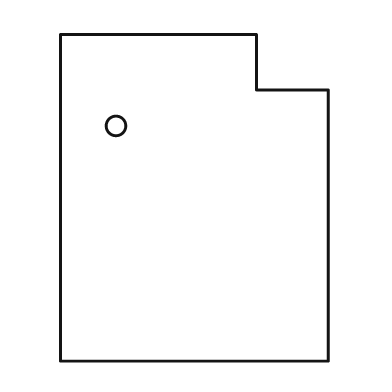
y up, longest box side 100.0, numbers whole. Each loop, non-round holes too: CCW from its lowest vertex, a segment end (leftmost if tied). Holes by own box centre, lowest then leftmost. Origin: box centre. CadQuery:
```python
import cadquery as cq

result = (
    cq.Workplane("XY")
    .moveTo(-41.0, -50.0)
    .lineTo(41.0, -50.0)
    .lineTo(41.0, 33.0)
    .lineTo(19.0, 33.0)
    .lineTo(19.0, 50.0)
    .lineTo(-41.0, 50.0)
    .close()
    .moveTo(-24.0, 22.0)
    .circle(3.0)
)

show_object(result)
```